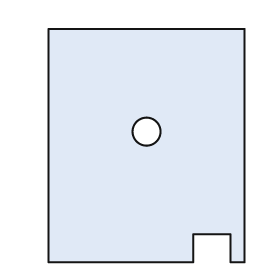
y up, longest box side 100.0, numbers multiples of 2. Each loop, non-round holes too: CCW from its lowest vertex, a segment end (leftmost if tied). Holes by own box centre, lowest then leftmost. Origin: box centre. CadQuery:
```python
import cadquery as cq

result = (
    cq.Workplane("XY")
    .moveTo(-42.0, -50.0)
    .lineTo(20.0, -50.0)
    .lineTo(20.0, -38.0)
    .lineTo(36.0, -38.0)
    .lineTo(36.0, -50.0)
    .lineTo(42.0, -50.0)
    .lineTo(42.0, 50.0)
    .lineTo(-42.0, 50.0)
    .close()
    .moveTo(0.0, 6.0)
    .circle(6.0)
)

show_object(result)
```